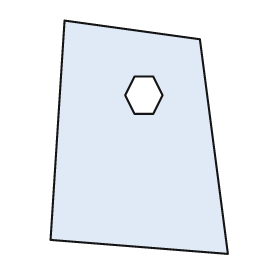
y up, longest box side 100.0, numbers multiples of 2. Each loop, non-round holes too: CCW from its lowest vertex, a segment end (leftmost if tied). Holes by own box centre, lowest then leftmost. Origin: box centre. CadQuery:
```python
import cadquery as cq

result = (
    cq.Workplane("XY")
    .moveTo(38.0, -50.0)
    .lineTo(26.0, 42.0)
    .lineTo(-32.0, 50.0)
    .lineTo(-38.0, -44.0)
    .close()
    .moveTo(-2.0, 10.0)
    .lineTo(6.0, 10.0)
    .lineTo(10.0, 18.0)
    .lineTo(6.0, 26.0)
    .lineTo(-2.0, 26.0)
    .lineTo(-6.0, 18.0)
    .close()
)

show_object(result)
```